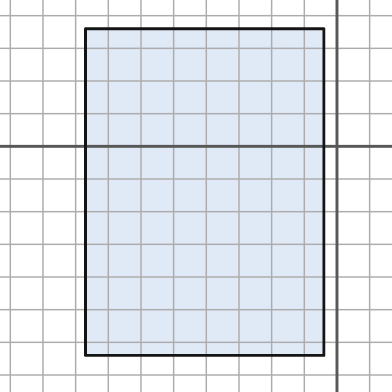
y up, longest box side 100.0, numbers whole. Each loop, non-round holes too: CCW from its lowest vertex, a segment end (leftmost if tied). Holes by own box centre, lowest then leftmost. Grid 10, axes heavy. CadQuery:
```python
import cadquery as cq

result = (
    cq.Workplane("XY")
    .moveTo(-77.0, -64.0)
    .lineTo(-4.0, -64.0)
    .lineTo(-4.0, 36.0)
    .lineTo(-77.0, 36.0)
    .close()
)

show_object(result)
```